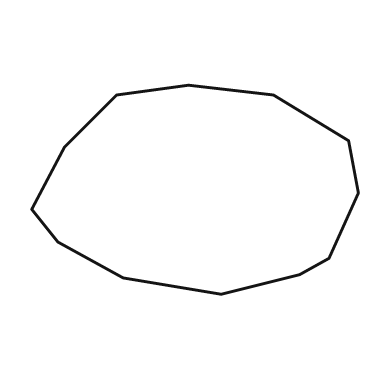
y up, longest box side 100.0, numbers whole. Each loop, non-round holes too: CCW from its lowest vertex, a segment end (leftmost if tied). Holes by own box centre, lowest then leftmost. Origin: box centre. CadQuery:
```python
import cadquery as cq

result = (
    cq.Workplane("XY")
    .moveTo(8.0, -32.0)
    .lineTo(32.0, -26.0)
    .lineTo(41.0, -21.0)
    .lineTo(50.0, -1.0)
    .lineTo(47.0, 15.0)
    .lineTo(24.0, 29.0)
    .lineTo(-2.0, 32.0)
    .lineTo(-24.0, 29.0)
    .lineTo(-40.0, 13.0)
    .lineTo(-50.0, -6.0)
    .lineTo(-42.0, -16.0)
    .lineTo(-22.0, -27.0)
    .close()
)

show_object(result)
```